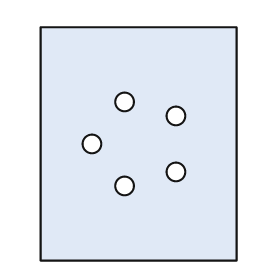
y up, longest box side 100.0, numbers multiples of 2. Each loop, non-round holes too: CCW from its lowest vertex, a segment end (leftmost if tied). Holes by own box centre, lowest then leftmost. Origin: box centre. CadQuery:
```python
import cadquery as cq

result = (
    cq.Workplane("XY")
    .moveTo(-42.0, -50.0)
    .lineTo(42.0, -50.0)
    .lineTo(42.0, 50.0)
    .lineTo(-42.0, 50.0)
    .close()
    .moveTo(-6.0, -18.0)
    .circle(4.0)
    .moveTo(16.0, -12.0)
    .circle(4.0)
    .moveTo(-20.0, 0.0)
    .circle(4.0)
    .moveTo(16.0, 12.0)
    .circle(4.0)
    .moveTo(-6.0, 18.0)
    .circle(4.0)
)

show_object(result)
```